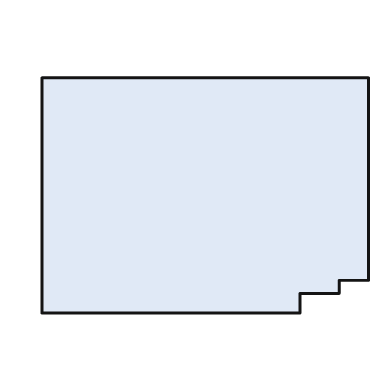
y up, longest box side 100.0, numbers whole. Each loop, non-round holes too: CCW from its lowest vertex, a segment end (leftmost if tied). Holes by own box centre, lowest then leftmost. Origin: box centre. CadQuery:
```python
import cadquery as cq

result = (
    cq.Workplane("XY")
    .moveTo(-50.0, -36.0)
    .lineTo(29.0, -36.0)
    .lineTo(29.0, -30.0)
    .lineTo(41.0, -30.0)
    .lineTo(41.0, -26.0)
    .lineTo(50.0, -26.0)
    .lineTo(50.0, 36.0)
    .lineTo(-50.0, 36.0)
    .close()
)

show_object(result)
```